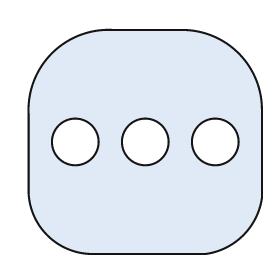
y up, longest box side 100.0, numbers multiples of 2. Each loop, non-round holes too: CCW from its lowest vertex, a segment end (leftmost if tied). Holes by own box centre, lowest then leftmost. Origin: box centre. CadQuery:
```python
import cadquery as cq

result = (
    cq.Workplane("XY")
    .moveTo(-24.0, -48.0)
    .lineTo(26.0, -48.0)
    .threePointArc((42.0, -40.0), (50.0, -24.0))
    .lineTo(50.0, 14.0)
    .threePointArc((40.0, 38.0), (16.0, 48.0))
    .lineTo(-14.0, 48.0)
    .threePointArc((-40.0, 38.0), (-50.0, 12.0))
    .lineTo(-50.0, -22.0)
    .threePointArc((-42.0, -40.0), (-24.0, -48.0))
    .close()
    .moveTo(-30.0, 0.0)
    .circle(10.0)
    .moveTo(0.0, 0.0)
    .circle(10.0)
    .moveTo(30.0, 0.0)
    .circle(10.0)
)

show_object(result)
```